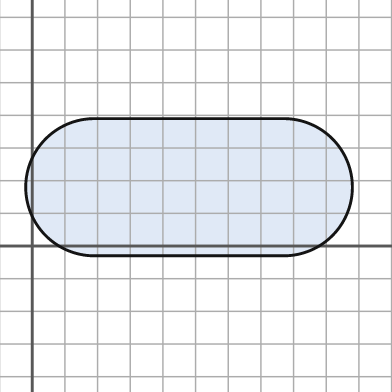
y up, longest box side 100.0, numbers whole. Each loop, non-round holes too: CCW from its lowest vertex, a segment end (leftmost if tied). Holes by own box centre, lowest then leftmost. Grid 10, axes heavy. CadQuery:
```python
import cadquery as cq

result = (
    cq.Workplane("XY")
    .moveTo(19.0, -3.0)
    .lineTo(77.0, -3.0)
    .threePointArc((98.0, 18.0), (77.0, 39.0))
    .lineTo(19.0, 39.0)
    .threePointArc((-2.0, 18.0), (19.0, -3.0))
    .close()
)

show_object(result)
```